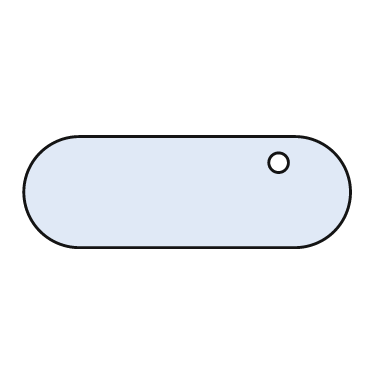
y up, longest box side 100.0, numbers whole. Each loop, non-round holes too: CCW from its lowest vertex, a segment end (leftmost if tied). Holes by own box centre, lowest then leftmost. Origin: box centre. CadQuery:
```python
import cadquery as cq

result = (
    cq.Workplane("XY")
    .moveTo(-33.0, -17.0)
    .lineTo(33.0, -17.0)
    .threePointArc((50.0, 0.0), (33.0, 17.0))
    .lineTo(-33.0, 17.0)
    .threePointArc((-50.0, 0.0), (-33.0, -17.0))
    .close()
    .moveTo(28.0, 9.0)
    .circle(3.0)
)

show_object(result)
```